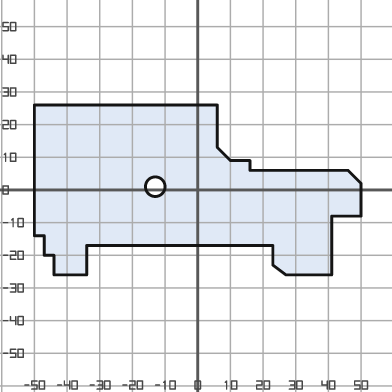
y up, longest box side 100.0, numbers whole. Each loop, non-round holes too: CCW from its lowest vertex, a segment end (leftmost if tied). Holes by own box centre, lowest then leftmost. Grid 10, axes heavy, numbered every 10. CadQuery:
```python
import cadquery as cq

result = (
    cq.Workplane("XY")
    .moveTo(-44.0, -26.0)
    .lineTo(-34.0, -26.0)
    .lineTo(-34.0, -17.0)
    .lineTo(23.0, -17.0)
    .lineTo(23.0, -23.0)
    .lineTo(27.0, -26.0)
    .lineTo(41.0, -26.0)
    .lineTo(41.0, -8.0)
    .lineTo(50.0, -8.0)
    .lineTo(50.0, 2.0)
    .lineTo(46.0, 6.0)
    .lineTo(16.0, 6.0)
    .lineTo(16.0, 9.0)
    .lineTo(10.0, 9.0)
    .lineTo(6.0, 13.0)
    .lineTo(6.0, 26.0)
    .lineTo(-50.0, 26.0)
    .lineTo(-50.0, -14.0)
    .lineTo(-47.0, -14.0)
    .lineTo(-47.0, -20.0)
    .lineTo(-44.0, -20.0)
    .close()
    .moveTo(-13.0, 1.0)
    .circle(3.0)
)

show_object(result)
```